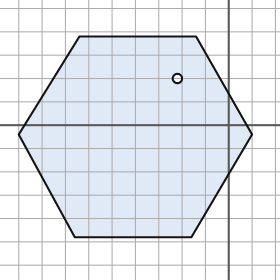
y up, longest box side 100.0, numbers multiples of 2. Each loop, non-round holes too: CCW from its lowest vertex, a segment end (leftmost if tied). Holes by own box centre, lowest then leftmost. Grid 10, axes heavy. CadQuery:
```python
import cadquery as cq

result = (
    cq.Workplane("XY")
    .moveTo(-66.0, -48.0)
    .lineTo(-16.0, -48.0)
    .lineTo(10.0, -4.0)
    .lineTo(-14.0, 38.0)
    .lineTo(-64.0, 38.0)
    .lineTo(-90.0, -4.0)
    .close()
    .moveTo(-22.0, 20.0)
    .circle(2.0)
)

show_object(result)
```